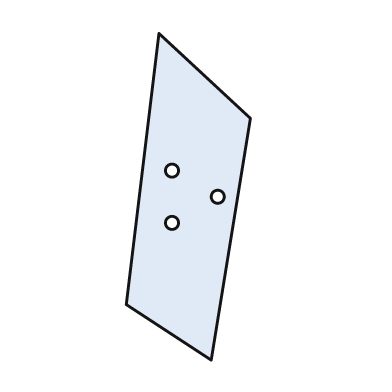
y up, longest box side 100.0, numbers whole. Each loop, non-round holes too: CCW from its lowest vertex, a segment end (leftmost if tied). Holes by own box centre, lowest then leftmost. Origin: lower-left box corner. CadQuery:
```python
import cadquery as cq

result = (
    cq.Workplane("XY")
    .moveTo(26.0, 0.0)
    .lineTo(38.0, 74.0)
    .lineTo(10.0, 100.0)
    .lineTo(0.0, 17.0)
    .close()
    .moveTo(14.0, 42.0)
    .circle(2.0)
    .moveTo(28.0, 50.0)
    .circle(2.0)
    .moveTo(14.0, 58.0)
    .circle(2.0)
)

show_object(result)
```